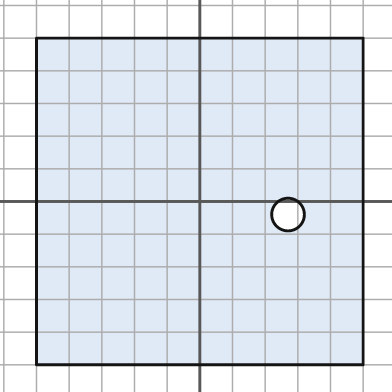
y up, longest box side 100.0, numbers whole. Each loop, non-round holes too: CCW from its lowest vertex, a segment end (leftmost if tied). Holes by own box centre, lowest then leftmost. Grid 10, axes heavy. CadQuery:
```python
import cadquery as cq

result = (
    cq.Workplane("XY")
    .moveTo(-50.0, -50.0)
    .lineTo(50.0, -50.0)
    .lineTo(50.0, 50.0)
    .lineTo(-50.0, 50.0)
    .close()
    .moveTo(27.0, -4.0)
    .circle(5.0)
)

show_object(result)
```